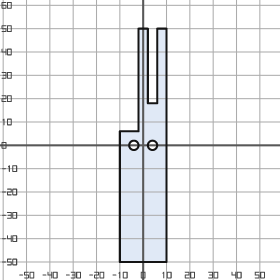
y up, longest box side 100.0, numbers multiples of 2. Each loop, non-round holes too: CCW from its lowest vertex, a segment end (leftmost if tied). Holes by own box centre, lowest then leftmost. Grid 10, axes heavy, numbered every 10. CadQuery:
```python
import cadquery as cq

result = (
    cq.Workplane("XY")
    .moveTo(-10.0, -50.0)
    .lineTo(10.0, -50.0)
    .lineTo(10.0, 50.0)
    .lineTo(6.0, 50.0)
    .lineTo(6.0, 18.0)
    .lineTo(2.0, 18.0)
    .lineTo(2.0, 50.0)
    .lineTo(-2.0, 50.0)
    .lineTo(-2.0, 6.0)
    .lineTo(-10.0, 6.0)
    .close()
    .moveTo(-4.0, 0.0)
    .circle(2.0)
    .moveTo(4.0, 0.0)
    .circle(2.0)
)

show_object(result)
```